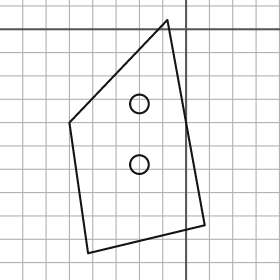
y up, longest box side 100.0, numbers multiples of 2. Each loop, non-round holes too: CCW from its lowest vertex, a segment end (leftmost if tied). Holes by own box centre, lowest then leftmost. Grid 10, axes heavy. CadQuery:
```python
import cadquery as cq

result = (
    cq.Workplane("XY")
    .moveTo(-42.0, -96.0)
    .lineTo(8.0, -84.0)
    .lineTo(-8.0, 4.0)
    .lineTo(-50.0, -40.0)
    .close()
    .moveTo(-20.0, -58.0)
    .circle(4.0)
    .moveTo(-20.0, -32.0)
    .circle(4.0)
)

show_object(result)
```